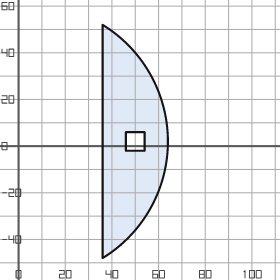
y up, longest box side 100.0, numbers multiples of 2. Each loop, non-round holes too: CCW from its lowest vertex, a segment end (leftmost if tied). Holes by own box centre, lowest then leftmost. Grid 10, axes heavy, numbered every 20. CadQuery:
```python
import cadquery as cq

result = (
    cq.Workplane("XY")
    .moveTo(36.0, -48.0)
    .threePointArc((64.0, 2.0), (36.0, 52.0))
    .close()
    .moveTo(46.0, -2.0)
    .lineTo(54.0, -2.0)
    .lineTo(54.0, 6.0)
    .lineTo(46.0, 6.0)
    .close()
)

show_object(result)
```